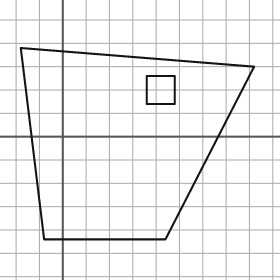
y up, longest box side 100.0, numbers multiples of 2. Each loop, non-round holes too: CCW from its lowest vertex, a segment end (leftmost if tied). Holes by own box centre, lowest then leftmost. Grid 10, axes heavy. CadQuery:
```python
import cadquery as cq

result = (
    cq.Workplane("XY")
    .moveTo(-8.0, -44.0)
    .lineTo(44.0, -44.0)
    .lineTo(82.0, 30.0)
    .lineTo(-18.0, 38.0)
    .close()
    .moveTo(36.0, 14.0)
    .lineTo(48.0, 14.0)
    .lineTo(48.0, 26.0)
    .lineTo(36.0, 26.0)
    .close()
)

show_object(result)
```